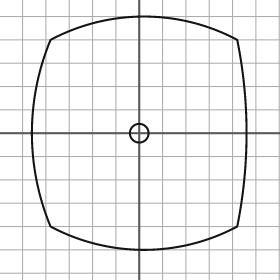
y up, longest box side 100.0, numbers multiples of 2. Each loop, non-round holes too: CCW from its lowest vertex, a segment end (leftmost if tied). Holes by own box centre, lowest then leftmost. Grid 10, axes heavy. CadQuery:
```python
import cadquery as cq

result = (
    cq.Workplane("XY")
    .moveTo(-38.0, -40.0)
    .threePointArc((2.0, -50.0), (42.0, -40.0))
    .threePointArc((46.0, 0.0), (42.0, 40.0))
    .threePointArc((2.0, 50.0), (-38.0, 40.0))
    .threePointArc((-46.0, 0.0), (-38.0, -40.0))
    .close()
    .moveTo(0.0, 0.0)
    .circle(4.0)
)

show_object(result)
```